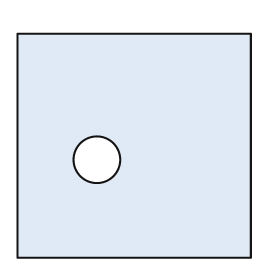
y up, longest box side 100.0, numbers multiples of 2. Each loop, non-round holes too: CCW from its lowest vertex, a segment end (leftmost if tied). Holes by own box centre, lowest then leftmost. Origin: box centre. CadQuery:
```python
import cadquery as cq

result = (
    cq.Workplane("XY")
    .moveTo(-50.0, -48.0)
    .lineTo(50.0, -48.0)
    .lineTo(50.0, 48.0)
    .lineTo(-50.0, 48.0)
    .close()
    .moveTo(-16.0, -6.0)
    .circle(10.0)
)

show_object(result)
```